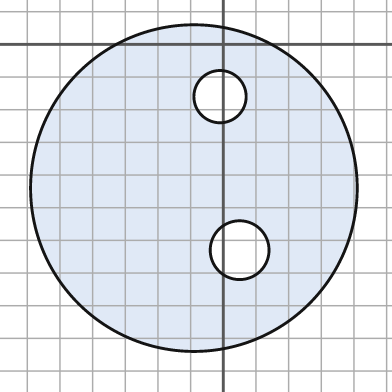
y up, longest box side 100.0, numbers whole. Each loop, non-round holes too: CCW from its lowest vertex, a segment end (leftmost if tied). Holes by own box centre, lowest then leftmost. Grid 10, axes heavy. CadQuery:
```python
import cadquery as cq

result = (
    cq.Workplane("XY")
    .moveTo(-9.0, -44.0)
    .circle(50.0)
    .moveTo(5.0, -63.0)
    .circle(9.0)
    .moveTo(-1.0, -16.0)
    .circle(8.0)
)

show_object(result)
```